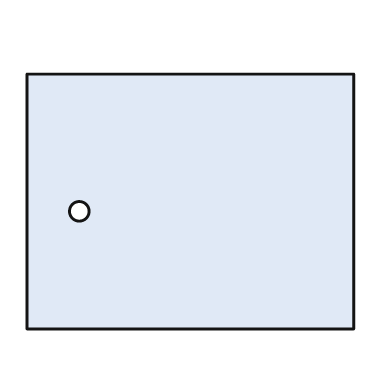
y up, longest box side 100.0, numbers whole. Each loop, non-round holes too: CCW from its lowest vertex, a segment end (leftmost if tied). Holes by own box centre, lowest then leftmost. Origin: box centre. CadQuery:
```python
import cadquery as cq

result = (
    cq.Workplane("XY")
    .moveTo(-50.0, -39.0)
    .lineTo(50.0, -39.0)
    .lineTo(50.0, 39.0)
    .lineTo(-50.0, 39.0)
    .close()
    .moveTo(-34.0, -3.0)
    .circle(3.0)
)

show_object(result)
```